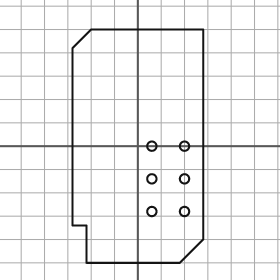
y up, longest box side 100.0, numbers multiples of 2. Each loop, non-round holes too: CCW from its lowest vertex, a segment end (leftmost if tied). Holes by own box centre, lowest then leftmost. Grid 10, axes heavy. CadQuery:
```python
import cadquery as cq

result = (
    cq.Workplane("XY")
    .moveTo(-22.0, -50.0)
    .lineTo(18.0, -50.0)
    .lineTo(28.0, -40.0)
    .lineTo(28.0, 50.0)
    .lineTo(-20.0, 50.0)
    .lineTo(-28.0, 42.0)
    .lineTo(-28.0, -34.0)
    .lineTo(-22.0, -34.0)
    .close()
    .moveTo(6.0, -28.0)
    .circle(2.0)
    .moveTo(20.0, -28.0)
    .circle(2.0)
    .moveTo(6.0, -14.0)
    .circle(2.0)
    .moveTo(20.0, -14.0)
    .circle(2.0)
    .moveTo(6.0, 0.0)
    .circle(2.0)
    .moveTo(20.0, 0.0)
    .circle(2.0)
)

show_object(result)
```